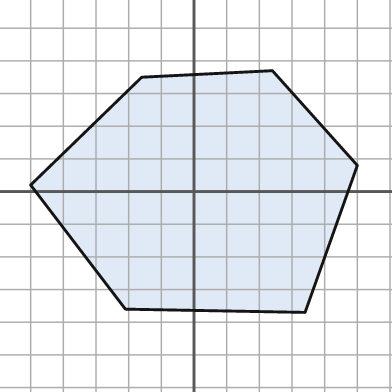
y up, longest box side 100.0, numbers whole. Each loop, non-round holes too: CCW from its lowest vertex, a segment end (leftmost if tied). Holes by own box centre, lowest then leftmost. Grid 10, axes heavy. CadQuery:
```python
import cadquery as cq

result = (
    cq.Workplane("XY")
    .moveTo(34.0, -37.0)
    .lineTo(50.0, 8.0)
    .lineTo(24.0, 37.0)
    .lineTo(-16.0, 35.0)
    .lineTo(-50.0, 2.0)
    .lineTo(-21.0, -36.0)
    .close()
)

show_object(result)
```